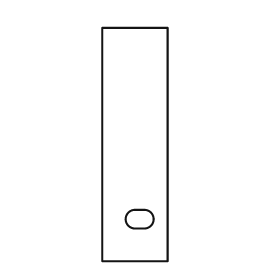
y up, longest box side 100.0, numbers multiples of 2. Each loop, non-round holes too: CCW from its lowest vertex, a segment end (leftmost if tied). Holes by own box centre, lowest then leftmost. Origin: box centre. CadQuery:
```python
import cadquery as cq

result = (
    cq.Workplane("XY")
    .moveTo(-14.0, -50.0)
    .lineTo(14.0, -50.0)
    .lineTo(14.0, 50.0)
    .lineTo(-14.0, 50.0)
    .close()
    .moveTo(0.0, -36.0)
    .lineTo(4.0, -36.0)
    .threePointArc((8.0, -32.0), (4.0, -28.0))
    .lineTo(0.0, -28.0)
    .threePointArc((-4.0, -32.0), (0.0, -36.0))
    .close()
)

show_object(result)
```